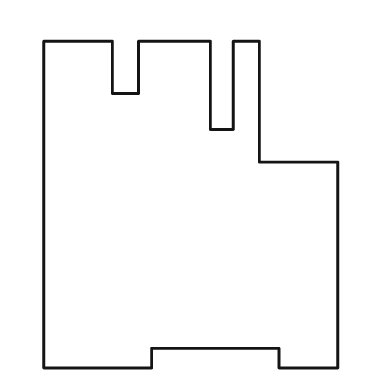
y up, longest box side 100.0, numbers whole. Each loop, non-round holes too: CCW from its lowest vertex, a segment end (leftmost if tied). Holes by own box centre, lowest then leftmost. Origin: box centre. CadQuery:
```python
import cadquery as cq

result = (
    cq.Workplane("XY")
    .moveTo(-45.0, -50.0)
    .lineTo(-12.0, -50.0)
    .lineTo(-12.0, -44.0)
    .lineTo(27.0, -44.0)
    .lineTo(27.0, -50.0)
    .lineTo(45.0, -50.0)
    .lineTo(45.0, 13.0)
    .lineTo(21.0, 13.0)
    .lineTo(21.0, 50.0)
    .lineTo(13.0, 50.0)
    .lineTo(13.0, 23.0)
    .lineTo(6.0, 23.0)
    .lineTo(6.0, 50.0)
    .lineTo(-16.0, 50.0)
    .lineTo(-16.0, 34.0)
    .lineTo(-24.0, 34.0)
    .lineTo(-24.0, 50.0)
    .lineTo(-45.0, 50.0)
    .close()
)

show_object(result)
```